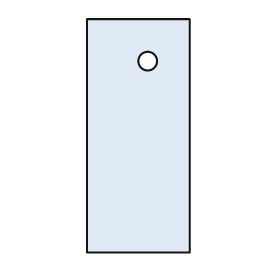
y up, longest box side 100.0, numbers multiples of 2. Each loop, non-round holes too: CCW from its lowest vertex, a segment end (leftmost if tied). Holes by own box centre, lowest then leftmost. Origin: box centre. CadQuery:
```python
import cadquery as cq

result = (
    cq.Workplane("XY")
    .moveTo(-22.0, -50.0)
    .lineTo(22.0, -50.0)
    .lineTo(22.0, 50.0)
    .lineTo(-22.0, 50.0)
    .close()
    .moveTo(4.0, 32.0)
    .circle(4.0)
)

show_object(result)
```